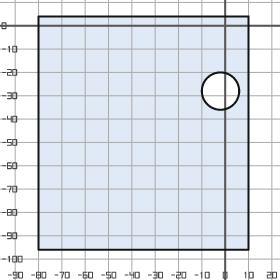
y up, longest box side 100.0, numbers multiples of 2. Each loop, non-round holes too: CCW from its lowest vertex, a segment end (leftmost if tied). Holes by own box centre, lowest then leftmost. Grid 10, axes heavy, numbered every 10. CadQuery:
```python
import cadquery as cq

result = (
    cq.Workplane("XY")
    .moveTo(-80.0, -96.0)
    .lineTo(10.0, -96.0)
    .lineTo(10.0, 4.0)
    .lineTo(-80.0, 4.0)
    .close()
    .moveTo(-2.0, -28.0)
    .circle(8.0)
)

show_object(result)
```